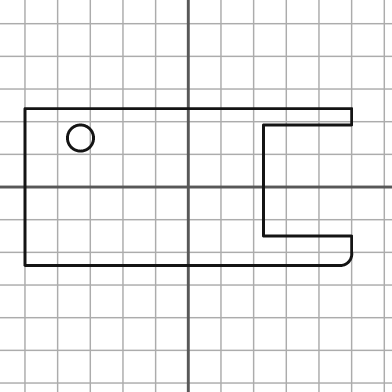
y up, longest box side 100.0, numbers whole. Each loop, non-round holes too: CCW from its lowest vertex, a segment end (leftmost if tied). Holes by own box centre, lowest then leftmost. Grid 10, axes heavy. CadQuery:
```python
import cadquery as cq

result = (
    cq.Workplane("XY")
    .moveTo(-50.0, -24.0)
    .lineTo(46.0, -24.0)
    .threePointArc((49.0, -23.0), (50.0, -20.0))
    .lineTo(50.0, -15.0)
    .lineTo(23.0, -15.0)
    .lineTo(23.0, 19.0)
    .lineTo(50.0, 19.0)
    .lineTo(50.0, 24.0)
    .lineTo(-50.0, 24.0)
    .close()
    .moveTo(-33.0, 15.0)
    .circle(4.0)
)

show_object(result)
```